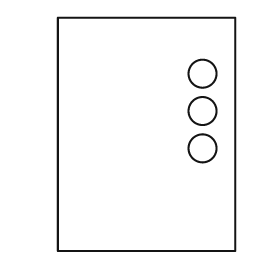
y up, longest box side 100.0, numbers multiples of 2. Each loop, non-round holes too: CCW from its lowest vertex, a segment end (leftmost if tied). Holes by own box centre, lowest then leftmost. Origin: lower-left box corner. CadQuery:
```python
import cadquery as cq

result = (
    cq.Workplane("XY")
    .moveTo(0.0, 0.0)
    .lineTo(76.0, 0.0)
    .lineTo(76.0, 100.0)
    .lineTo(0.0, 100.0)
    .close()
    .moveTo(62.0, 44.0)
    .circle(6.0)
    .moveTo(62.0, 60.0)
    .circle(6.0)
    .moveTo(62.0, 76.0)
    .circle(6.0)
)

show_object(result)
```